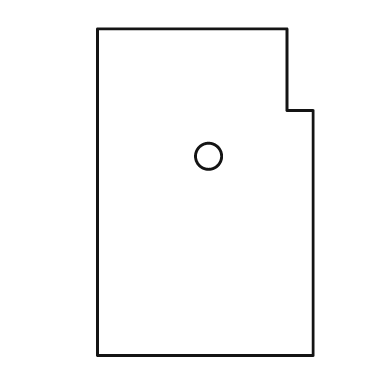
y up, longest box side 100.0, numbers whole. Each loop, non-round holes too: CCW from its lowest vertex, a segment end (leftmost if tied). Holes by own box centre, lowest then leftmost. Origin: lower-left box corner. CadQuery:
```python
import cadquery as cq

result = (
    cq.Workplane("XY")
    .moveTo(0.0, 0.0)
    .lineTo(66.0, 0.0)
    .lineTo(66.0, 75.0)
    .lineTo(58.0, 75.0)
    .lineTo(58.0, 100.0)
    .lineTo(0.0, 100.0)
    .close()
    .moveTo(34.0, 61.0)
    .circle(4.0)
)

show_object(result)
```